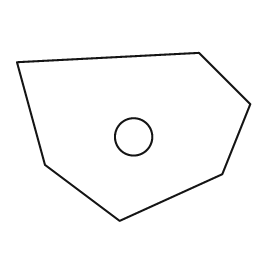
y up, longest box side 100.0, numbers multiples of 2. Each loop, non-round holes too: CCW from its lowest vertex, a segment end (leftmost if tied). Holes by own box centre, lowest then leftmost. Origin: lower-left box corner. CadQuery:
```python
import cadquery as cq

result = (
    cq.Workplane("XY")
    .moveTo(44.0, 0.0)
    .lineTo(88.0, 20.0)
    .lineTo(100.0, 50.0)
    .lineTo(78.0, 72.0)
    .lineTo(0.0, 68.0)
    .lineTo(12.0, 24.0)
    .close()
    .moveTo(50.0, 36.0)
    .circle(8.0)
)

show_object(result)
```